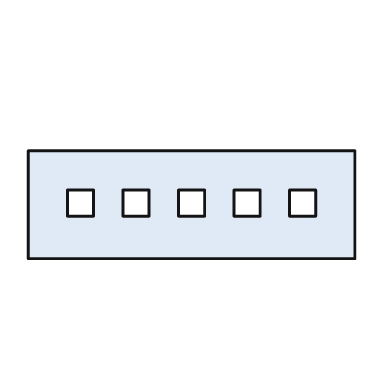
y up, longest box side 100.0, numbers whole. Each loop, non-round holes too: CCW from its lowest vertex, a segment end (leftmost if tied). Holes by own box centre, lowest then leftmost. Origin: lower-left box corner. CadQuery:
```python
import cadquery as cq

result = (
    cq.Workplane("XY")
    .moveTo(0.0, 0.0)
    .lineTo(100.0, 0.0)
    .lineTo(100.0, 33.0)
    .lineTo(0.0, 33.0)
    .close()
    .moveTo(12.0, 13.0)
    .lineTo(20.0, 13.0)
    .lineTo(20.0, 21.0)
    .lineTo(12.0, 21.0)
    .close()
    .moveTo(29.0, 13.0)
    .lineTo(37.0, 13.0)
    .lineTo(37.0, 21.0)
    .lineTo(29.0, 21.0)
    .close()
    .moveTo(46.0, 13.0)
    .lineTo(54.0, 13.0)
    .lineTo(54.0, 21.0)
    .lineTo(46.0, 21.0)
    .close()
    .moveTo(63.0, 13.0)
    .lineTo(71.0, 13.0)
    .lineTo(71.0, 21.0)
    .lineTo(63.0, 21.0)
    .close()
    .moveTo(80.0, 13.0)
    .lineTo(88.0, 13.0)
    .lineTo(88.0, 21.0)
    .lineTo(80.0, 21.0)
    .close()
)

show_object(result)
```